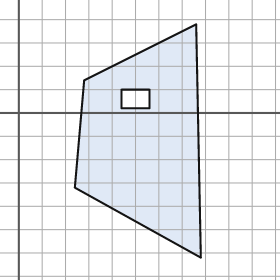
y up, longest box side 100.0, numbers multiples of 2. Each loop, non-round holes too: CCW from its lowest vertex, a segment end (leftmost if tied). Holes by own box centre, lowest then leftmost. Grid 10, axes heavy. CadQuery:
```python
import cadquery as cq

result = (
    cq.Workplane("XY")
    .moveTo(78.0, -62.0)
    .lineTo(76.0, 38.0)
    .lineTo(28.0, 14.0)
    .lineTo(24.0, -32.0)
    .close()
    .moveTo(44.0, 2.0)
    .lineTo(56.0, 2.0)
    .lineTo(56.0, 10.0)
    .lineTo(44.0, 10.0)
    .close()
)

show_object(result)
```